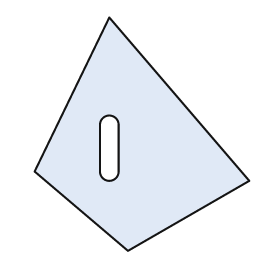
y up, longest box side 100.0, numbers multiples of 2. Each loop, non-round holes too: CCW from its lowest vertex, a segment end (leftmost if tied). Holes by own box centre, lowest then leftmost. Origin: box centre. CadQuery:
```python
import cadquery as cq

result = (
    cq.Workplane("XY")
    .moveTo(-6.0, -50.0)
    .lineTo(46.0, -20.0)
    .lineTo(-14.0, 50.0)
    .lineTo(-46.0, -16.0)
    .close()
    .moveTo(-18.0, -16.0)
    .threePointArc((-14.0, -20.0), (-10.0, -16.0))
    .lineTo(-10.0, 4.0)
    .threePointArc((-14.0, 8.0), (-18.0, 4.0))
    .close()
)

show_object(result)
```